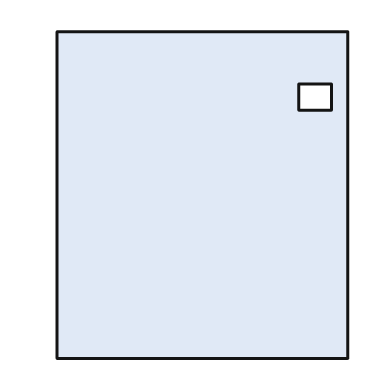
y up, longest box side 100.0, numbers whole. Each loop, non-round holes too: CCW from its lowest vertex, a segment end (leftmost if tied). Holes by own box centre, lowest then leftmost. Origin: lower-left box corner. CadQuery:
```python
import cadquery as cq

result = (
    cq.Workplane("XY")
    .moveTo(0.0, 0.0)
    .lineTo(89.0, 0.0)
    .lineTo(89.0, 100.0)
    .lineTo(0.0, 100.0)
    .close()
    .moveTo(74.0, 76.0)
    .lineTo(84.0, 76.0)
    .lineTo(84.0, 84.0)
    .lineTo(74.0, 84.0)
    .close()
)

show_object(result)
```